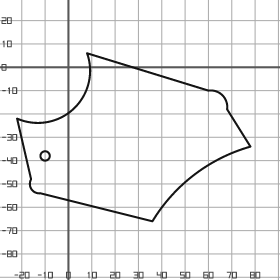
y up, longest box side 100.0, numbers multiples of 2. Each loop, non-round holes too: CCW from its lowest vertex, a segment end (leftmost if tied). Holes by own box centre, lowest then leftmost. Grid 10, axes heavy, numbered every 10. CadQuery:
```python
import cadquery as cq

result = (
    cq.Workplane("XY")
    .moveTo(36.0, -66.0)
    .threePointArc((54.0, -46.0), (78.0, -34.0))
    .lineTo(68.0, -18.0)
    .threePointArc((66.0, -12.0), (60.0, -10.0))
    .lineTo(8.0, 6.0)
    .threePointArc((2.0, -18.0), (-22.0, -22.0))
    .lineTo(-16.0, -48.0)
    .threePointArc((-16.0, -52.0), (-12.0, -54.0))
    .close()
    .moveTo(-10.0, -38.0)
    .circle(2.0)
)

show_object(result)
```